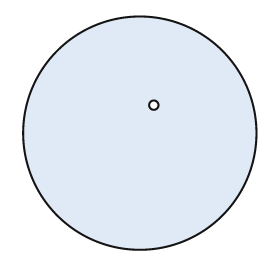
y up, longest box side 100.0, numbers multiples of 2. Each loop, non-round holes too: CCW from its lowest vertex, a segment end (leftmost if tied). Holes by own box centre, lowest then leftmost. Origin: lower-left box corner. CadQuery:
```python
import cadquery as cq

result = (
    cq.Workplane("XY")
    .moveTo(50.0, 50.0)
    .circle(50.0)
    .moveTo(56.0, 62.0)
    .circle(2.0)
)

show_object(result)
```